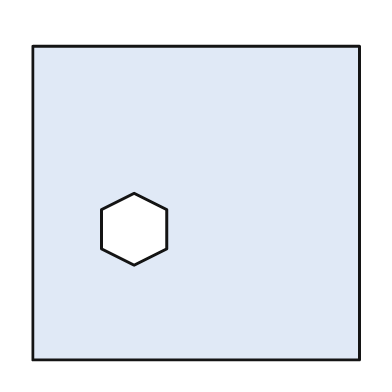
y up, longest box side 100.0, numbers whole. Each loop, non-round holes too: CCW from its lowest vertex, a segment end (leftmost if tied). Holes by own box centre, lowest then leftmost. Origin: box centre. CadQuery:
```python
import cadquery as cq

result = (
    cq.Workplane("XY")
    .moveTo(-50.0, -48.0)
    .lineTo(50.0, -48.0)
    .lineTo(50.0, 48.0)
    .lineTo(-50.0, 48.0)
    .close()
    .moveTo(-19.0, -19.0)
    .lineTo(-9.0, -14.0)
    .lineTo(-9.0, -2.0)
    .lineTo(-19.0, 3.0)
    .lineTo(-29.0, -2.0)
    .lineTo(-29.0, -14.0)
    .close()
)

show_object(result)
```